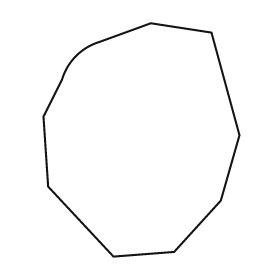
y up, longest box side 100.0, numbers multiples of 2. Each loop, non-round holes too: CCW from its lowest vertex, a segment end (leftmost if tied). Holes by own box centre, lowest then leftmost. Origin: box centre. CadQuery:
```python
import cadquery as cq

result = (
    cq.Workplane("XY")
    .moveTo(-12.0, -50.0)
    .lineTo(14.0, -48.0)
    .lineTo(34.0, -26.0)
    .lineTo(42.0, 2.0)
    .lineTo(30.0, 46.0)
    .lineTo(4.0, 50.0)
    .lineTo(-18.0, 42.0)
    .threePointArc((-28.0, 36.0), (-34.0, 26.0))
    .lineTo(-42.0, 10.0)
    .lineTo(-40.0, -20.0)
    .close()
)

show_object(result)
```